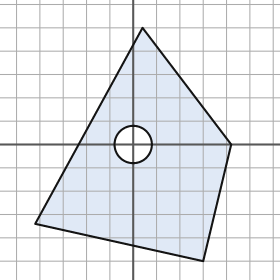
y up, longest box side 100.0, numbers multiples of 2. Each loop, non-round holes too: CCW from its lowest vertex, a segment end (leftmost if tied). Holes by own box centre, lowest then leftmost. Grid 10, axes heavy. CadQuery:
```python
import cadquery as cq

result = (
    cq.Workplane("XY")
    .moveTo(30.0, -50.0)
    .lineTo(42.0, 0.0)
    .lineTo(4.0, 50.0)
    .lineTo(-42.0, -34.0)
    .close()
    .moveTo(0.0, 0.0)
    .circle(8.0)
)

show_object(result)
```